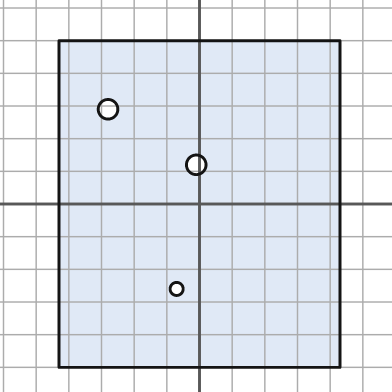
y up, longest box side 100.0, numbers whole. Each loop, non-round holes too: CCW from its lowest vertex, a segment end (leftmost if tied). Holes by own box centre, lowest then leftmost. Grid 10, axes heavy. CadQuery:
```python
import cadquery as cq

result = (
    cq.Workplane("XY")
    .moveTo(-43.0, -50.0)
    .lineTo(43.0, -50.0)
    .lineTo(43.0, 50.0)
    .lineTo(-43.0, 50.0)
    .close()
    .moveTo(-7.0, -26.0)
    .circle(2.0)
    .moveTo(-1.0, 12.0)
    .circle(3.0)
    .moveTo(-28.0, 29.0)
    .circle(3.0)
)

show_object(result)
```